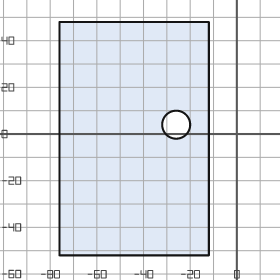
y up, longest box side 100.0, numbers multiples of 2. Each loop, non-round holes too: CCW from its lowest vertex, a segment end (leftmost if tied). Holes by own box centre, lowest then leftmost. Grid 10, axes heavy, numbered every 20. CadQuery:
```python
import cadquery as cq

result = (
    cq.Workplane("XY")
    .moveTo(-76.0, -52.0)
    .lineTo(-12.0, -52.0)
    .lineTo(-12.0, 48.0)
    .lineTo(-76.0, 48.0)
    .close()
    .moveTo(-26.0, 4.0)
    .circle(6.0)
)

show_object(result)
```